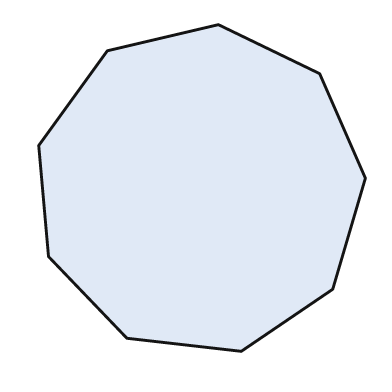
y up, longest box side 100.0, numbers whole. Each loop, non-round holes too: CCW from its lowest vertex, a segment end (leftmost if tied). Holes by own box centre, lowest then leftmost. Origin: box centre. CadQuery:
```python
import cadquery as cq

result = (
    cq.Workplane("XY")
    .moveTo(12.0, -50.0)
    .lineTo(40.0, -31.0)
    .lineTo(50.0, 3.0)
    .lineTo(36.0, 35.0)
    .lineTo(5.0, 50.0)
    .lineTo(-29.0, 42.0)
    .lineTo(-50.0, 13.0)
    .lineTo(-47.0, -21.0)
    .lineTo(-23.0, -46.0)
    .close()
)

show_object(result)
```